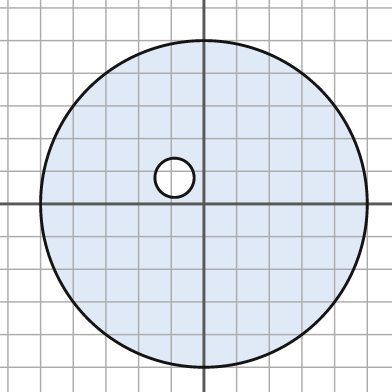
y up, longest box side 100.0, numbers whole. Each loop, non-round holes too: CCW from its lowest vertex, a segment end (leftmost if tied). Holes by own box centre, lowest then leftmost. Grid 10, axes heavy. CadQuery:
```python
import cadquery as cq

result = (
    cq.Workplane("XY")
    .moveTo(0.0, 0.0)
    .circle(50.0)
    .moveTo(-9.0, 8.0)
    .circle(6.0)
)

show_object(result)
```